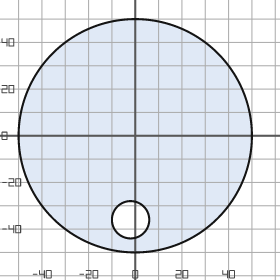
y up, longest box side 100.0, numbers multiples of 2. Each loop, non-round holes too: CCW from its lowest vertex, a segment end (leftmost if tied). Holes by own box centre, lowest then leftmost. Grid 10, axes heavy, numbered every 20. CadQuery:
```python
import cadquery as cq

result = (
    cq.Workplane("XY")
    .moveTo(0.0, 0.0)
    .circle(50.0)
    .moveTo(-2.0, -36.0)
    .circle(8.0)
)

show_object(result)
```